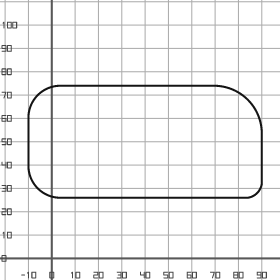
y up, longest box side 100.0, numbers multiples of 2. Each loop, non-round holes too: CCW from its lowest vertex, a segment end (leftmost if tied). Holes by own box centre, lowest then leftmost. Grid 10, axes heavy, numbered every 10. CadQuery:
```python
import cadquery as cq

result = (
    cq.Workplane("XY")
    .moveTo(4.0, 26.0)
    .lineTo(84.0, 26.0)
    .threePointArc((88.0, 28.0), (90.0, 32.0))
    .lineTo(90.0, 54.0)
    .threePointArc((84.0, 68.0), (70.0, 74.0))
    .lineTo(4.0, 74.0)
    .threePointArc((-6.0, 70.0), (-10.0, 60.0))
    .lineTo(-10.0, 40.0)
    .threePointArc((-6.0, 30.0), (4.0, 26.0))
    .close()
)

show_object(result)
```